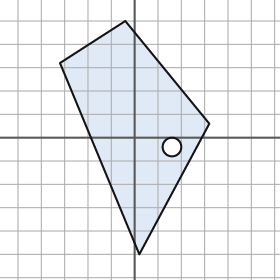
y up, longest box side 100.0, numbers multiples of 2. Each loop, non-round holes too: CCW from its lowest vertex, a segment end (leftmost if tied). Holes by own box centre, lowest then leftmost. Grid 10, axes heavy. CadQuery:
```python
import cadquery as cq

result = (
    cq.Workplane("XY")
    .moveTo(2.0, -50.0)
    .lineTo(32.0, 6.0)
    .lineTo(-4.0, 50.0)
    .lineTo(-32.0, 32.0)
    .close()
    .moveTo(16.0, -4.0)
    .circle(4.0)
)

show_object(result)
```